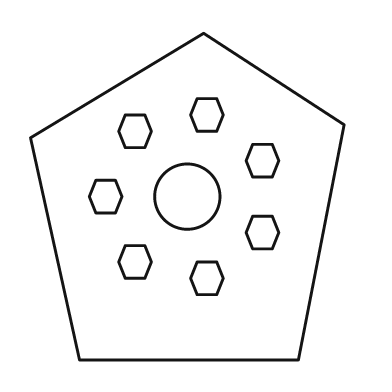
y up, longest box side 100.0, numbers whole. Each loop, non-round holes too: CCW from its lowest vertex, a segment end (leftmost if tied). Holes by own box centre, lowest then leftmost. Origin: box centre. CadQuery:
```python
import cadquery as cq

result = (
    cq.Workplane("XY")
    .moveTo(-33.0, -50.0)
    .lineTo(34.0, -50.0)
    .lineTo(48.0, 22.0)
    .lineTo(5.0, 50.0)
    .lineTo(-48.0, 18.0)
    .close()
    .moveTo(3.0, -30.0)
    .lineTo(9.0, -30.0)
    .lineTo(11.0, -25.0)
    .lineTo(9.0, -20.0)
    .lineTo(3.0, -20.0)
    .lineTo(1.0, -25.0)
    .close()
    .moveTo(-19.0, -25.0)
    .lineTo(-13.0, -25.0)
    .lineTo(-11.0, -20.0)
    .lineTo(-13.0, -15.0)
    .lineTo(-19.0, -15.0)
    .lineTo(-21.0, -20.0)
    .close()
    .moveTo(20.0, -16.0)
    .lineTo(26.0, -16.0)
    .lineTo(28.0, -11.0)
    .lineTo(26.0, -6.0)
    .lineTo(20.0, -6.0)
    .lineTo(18.0, -11.0)
    .close()
    .moveTo(-28.0, -5.0)
    .lineTo(-22.0, -5.0)
    .lineTo(-20.0, 0.0)
    .lineTo(-22.0, 5.0)
    .lineTo(-28.0, 5.0)
    .lineTo(-30.0, 0.0)
    .close()
    .moveTo(0.0, 0.0)
    .circle(10.0)
    .moveTo(20.0, 6.0)
    .lineTo(26.0, 6.0)
    .lineTo(28.0, 11.0)
    .lineTo(26.0, 16.0)
    .lineTo(20.0, 16.0)
    .lineTo(18.0, 11.0)
    .close()
    .moveTo(-19.0, 15.0)
    .lineTo(-13.0, 15.0)
    .lineTo(-11.0, 20.0)
    .lineTo(-13.0, 25.0)
    .lineTo(-19.0, 25.0)
    .lineTo(-21.0, 20.0)
    .close()
    .moveTo(3.0, 20.0)
    .lineTo(9.0, 20.0)
    .lineTo(11.0, 25.0)
    .lineTo(9.0, 30.0)
    .lineTo(3.0, 30.0)
    .lineTo(1.0, 25.0)
    .close()
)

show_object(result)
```